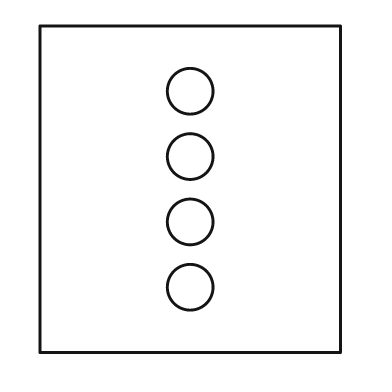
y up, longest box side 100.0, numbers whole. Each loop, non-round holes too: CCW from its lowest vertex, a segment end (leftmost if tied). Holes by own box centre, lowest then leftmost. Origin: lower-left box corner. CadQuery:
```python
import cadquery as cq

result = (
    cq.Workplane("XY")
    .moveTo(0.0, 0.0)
    .lineTo(92.0, 0.0)
    .lineTo(92.0, 100.0)
    .lineTo(0.0, 100.0)
    .close()
    .moveTo(46.0, 20.0)
    .circle(7.0)
    .moveTo(46.0, 40.0)
    .circle(7.0)
    .moveTo(46.0, 60.0)
    .circle(7.0)
    .moveTo(46.0, 80.0)
    .circle(7.0)
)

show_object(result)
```